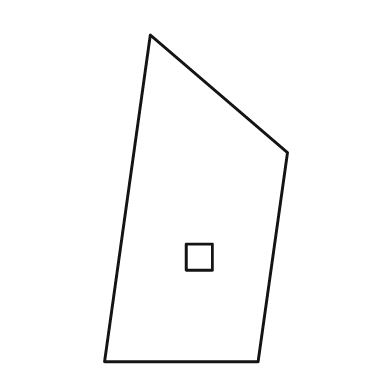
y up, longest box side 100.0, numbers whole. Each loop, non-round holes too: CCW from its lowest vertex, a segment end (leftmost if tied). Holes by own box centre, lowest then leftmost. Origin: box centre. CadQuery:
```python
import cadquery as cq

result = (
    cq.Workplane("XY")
    .moveTo(-28.0, -50.0)
    .lineTo(19.0, -50.0)
    .lineTo(28.0, 14.0)
    .lineTo(-14.0, 50.0)
    .close()
    .moveTo(-3.0, -22.0)
    .lineTo(5.0, -22.0)
    .lineTo(5.0, -14.0)
    .lineTo(-3.0, -14.0)
    .close()
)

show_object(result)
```